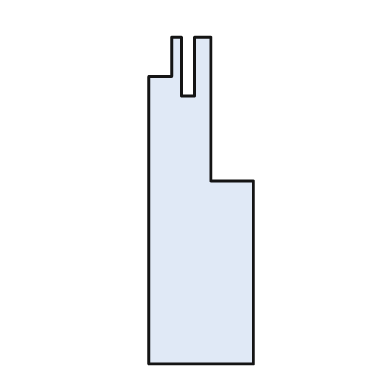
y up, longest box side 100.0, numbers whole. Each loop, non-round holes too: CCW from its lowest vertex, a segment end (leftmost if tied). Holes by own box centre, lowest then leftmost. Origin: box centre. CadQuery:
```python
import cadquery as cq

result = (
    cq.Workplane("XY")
    .moveTo(-16.0, -50.0)
    .lineTo(16.0, -50.0)
    .lineTo(16.0, 6.0)
    .lineTo(3.0, 6.0)
    .lineTo(3.0, 50.0)
    .lineTo(-2.0, 50.0)
    .lineTo(-2.0, 32.0)
    .lineTo(-6.0, 32.0)
    .lineTo(-6.0, 50.0)
    .lineTo(-9.0, 50.0)
    .lineTo(-9.0, 38.0)
    .lineTo(-16.0, 38.0)
    .close()
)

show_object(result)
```